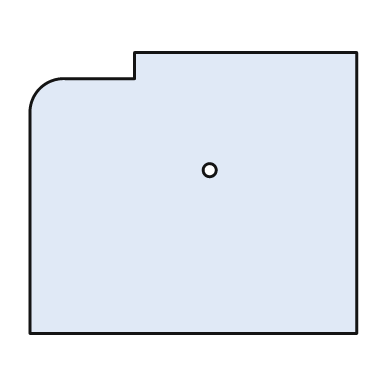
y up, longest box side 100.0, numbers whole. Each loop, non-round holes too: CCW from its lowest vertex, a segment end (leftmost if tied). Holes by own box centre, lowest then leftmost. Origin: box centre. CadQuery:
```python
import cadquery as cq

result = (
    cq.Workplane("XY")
    .moveTo(-50.0, -43.0)
    .lineTo(50.0, -43.0)
    .lineTo(50.0, 43.0)
    .lineTo(-18.0, 43.0)
    .lineTo(-18.0, 35.0)
    .lineTo(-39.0, 35.0)
    .threePointArc((-47.0, 32.0), (-50.0, 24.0))
    .close()
    .moveTo(5.0, 7.0)
    .circle(2.0)
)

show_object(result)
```